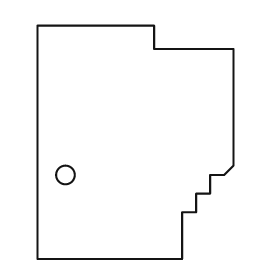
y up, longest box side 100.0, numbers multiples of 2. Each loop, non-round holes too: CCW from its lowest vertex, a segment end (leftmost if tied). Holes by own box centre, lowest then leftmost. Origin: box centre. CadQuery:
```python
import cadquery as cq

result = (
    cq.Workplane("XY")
    .moveTo(-42.0, -50.0)
    .lineTo(20.0, -50.0)
    .lineTo(20.0, -30.0)
    .lineTo(26.0, -30.0)
    .lineTo(26.0, -22.0)
    .lineTo(32.0, -22.0)
    .lineTo(32.0, -14.0)
    .lineTo(38.0, -14.0)
    .lineTo(42.0, -10.0)
    .lineTo(42.0, 40.0)
    .lineTo(8.0, 40.0)
    .lineTo(8.0, 50.0)
    .lineTo(-42.0, 50.0)
    .close()
    .moveTo(-30.0, -14.0)
    .circle(4.0)
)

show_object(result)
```